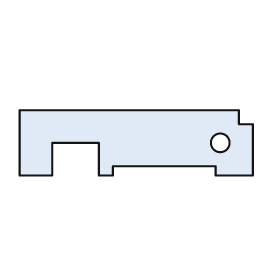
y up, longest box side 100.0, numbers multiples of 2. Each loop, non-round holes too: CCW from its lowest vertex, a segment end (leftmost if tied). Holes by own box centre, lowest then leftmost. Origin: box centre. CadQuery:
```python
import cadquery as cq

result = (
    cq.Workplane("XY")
    .moveTo(-50.0, -14.0)
    .lineTo(-36.0, -14.0)
    .lineTo(-36.0, 0.0)
    .lineTo(-16.0, 0.0)
    .lineTo(-16.0, -14.0)
    .lineTo(-10.0, -14.0)
    .lineTo(-10.0, -10.0)
    .lineTo(34.0, -10.0)
    .lineTo(34.0, -14.0)
    .lineTo(50.0, -14.0)
    .lineTo(50.0, 8.0)
    .lineTo(44.0, 8.0)
    .lineTo(44.0, 14.0)
    .lineTo(-50.0, 14.0)
    .close()
    .moveTo(36.0, 0.0)
    .circle(4.0)
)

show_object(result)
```